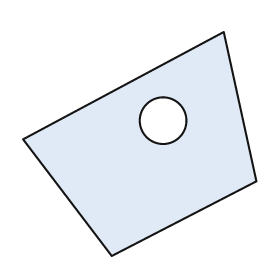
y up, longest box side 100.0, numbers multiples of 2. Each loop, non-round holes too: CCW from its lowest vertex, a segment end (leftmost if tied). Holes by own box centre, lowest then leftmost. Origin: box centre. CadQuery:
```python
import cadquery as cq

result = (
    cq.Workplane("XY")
    .moveTo(-12.0, -48.0)
    .lineTo(50.0, -16.0)
    .lineTo(36.0, 48.0)
    .lineTo(-50.0, 2.0)
    .close()
    .moveTo(10.0, 10.0)
    .circle(10.0)
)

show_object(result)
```